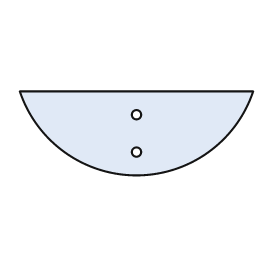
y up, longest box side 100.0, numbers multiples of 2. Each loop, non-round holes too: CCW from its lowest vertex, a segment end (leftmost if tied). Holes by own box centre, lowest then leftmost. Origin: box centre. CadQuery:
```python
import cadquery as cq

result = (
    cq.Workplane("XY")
    .moveTo(-50.0, 18.0)
    .threePointArc((0.0, -18.0), (50.0, 18.0))
    .close()
    .moveTo(0.0, -8.0)
    .circle(2.0)
    .moveTo(0.0, 8.0)
    .circle(2.0)
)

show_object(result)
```